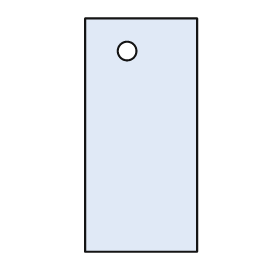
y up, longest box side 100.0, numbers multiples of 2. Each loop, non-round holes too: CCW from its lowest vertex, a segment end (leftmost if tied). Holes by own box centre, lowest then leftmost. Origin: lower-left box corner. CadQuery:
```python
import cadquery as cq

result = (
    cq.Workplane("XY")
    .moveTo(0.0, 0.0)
    .lineTo(48.0, 0.0)
    .lineTo(48.0, 100.0)
    .lineTo(0.0, 100.0)
    .close()
    .moveTo(18.0, 86.0)
    .circle(4.0)
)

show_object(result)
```